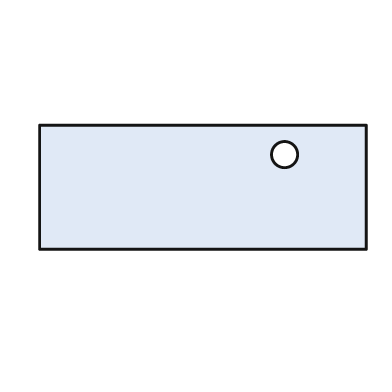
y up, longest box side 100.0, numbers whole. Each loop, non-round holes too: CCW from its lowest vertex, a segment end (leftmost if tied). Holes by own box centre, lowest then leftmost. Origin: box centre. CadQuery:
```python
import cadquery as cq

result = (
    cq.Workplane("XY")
    .moveTo(-50.0, -19.0)
    .lineTo(50.0, -19.0)
    .lineTo(50.0, 19.0)
    .lineTo(-50.0, 19.0)
    .close()
    .moveTo(25.0, 10.0)
    .circle(4.0)
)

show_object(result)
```